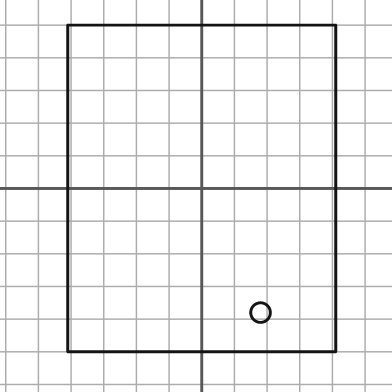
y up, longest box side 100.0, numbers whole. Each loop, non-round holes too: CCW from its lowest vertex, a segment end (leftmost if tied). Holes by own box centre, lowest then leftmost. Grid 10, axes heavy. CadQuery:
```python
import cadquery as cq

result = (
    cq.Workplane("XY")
    .moveTo(-41.0, -50.0)
    .lineTo(41.0, -50.0)
    .lineTo(41.0, 50.0)
    .lineTo(-41.0, 50.0)
    .close()
    .moveTo(18.0, -38.0)
    .circle(3.0)
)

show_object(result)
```